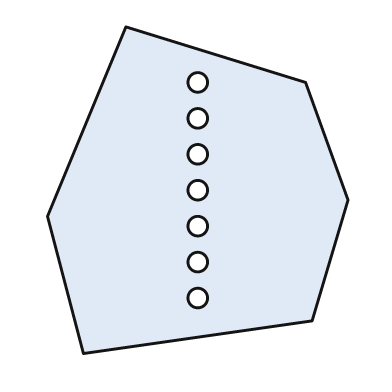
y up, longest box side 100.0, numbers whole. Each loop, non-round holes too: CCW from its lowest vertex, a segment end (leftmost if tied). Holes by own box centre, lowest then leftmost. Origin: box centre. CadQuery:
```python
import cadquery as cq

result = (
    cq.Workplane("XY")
    .moveTo(-35.0, -50.0)
    .lineTo(35.0, -40.0)
    .lineTo(46.0, -3.0)
    .lineTo(33.0, 33.0)
    .lineTo(-22.0, 50.0)
    .lineTo(-46.0, -8.0)
    .close()
    .moveTo(0.0, -33.0)
    .circle(3.0)
    .moveTo(0.0, -22.0)
    .circle(3.0)
    .moveTo(0.0, -11.0)
    .circle(3.0)
    .moveTo(0.0, 0.0)
    .circle(3.0)
    .moveTo(0.0, 11.0)
    .circle(3.0)
    .moveTo(0.0, 22.0)
    .circle(3.0)
    .moveTo(0.0, 33.0)
    .circle(3.0)
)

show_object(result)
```